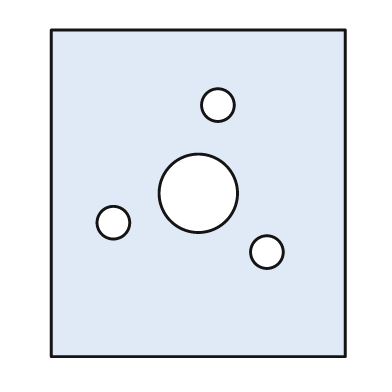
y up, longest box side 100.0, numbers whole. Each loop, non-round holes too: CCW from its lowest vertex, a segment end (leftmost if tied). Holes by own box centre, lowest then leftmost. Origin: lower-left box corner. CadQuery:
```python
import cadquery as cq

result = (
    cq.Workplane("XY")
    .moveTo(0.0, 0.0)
    .lineTo(90.0, 0.0)
    .lineTo(90.0, 100.0)
    .lineTo(0.0, 100.0)
    .close()
    .moveTo(66.0, 32.0)
    .circle(5.0)
    .moveTo(19.0, 41.0)
    .circle(5.0)
    .moveTo(45.0, 50.0)
    .circle(12.0)
    .moveTo(51.0, 77.0)
    .circle(5.0)
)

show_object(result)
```